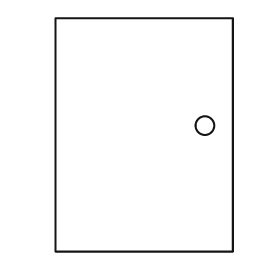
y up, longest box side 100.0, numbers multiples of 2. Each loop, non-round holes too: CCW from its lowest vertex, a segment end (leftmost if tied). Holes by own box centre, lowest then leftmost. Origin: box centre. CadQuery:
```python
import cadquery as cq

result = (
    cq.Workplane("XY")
    .moveTo(-38.0, -50.0)
    .lineTo(38.0, -50.0)
    .lineTo(38.0, 50.0)
    .lineTo(-38.0, 50.0)
    .close()
    .moveTo(26.0, 4.0)
    .circle(4.0)
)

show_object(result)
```